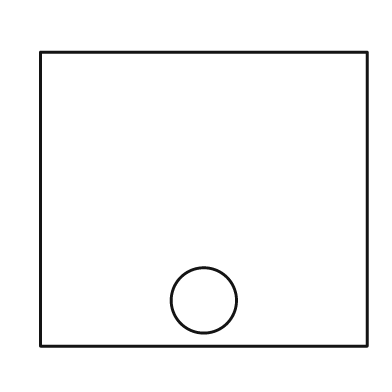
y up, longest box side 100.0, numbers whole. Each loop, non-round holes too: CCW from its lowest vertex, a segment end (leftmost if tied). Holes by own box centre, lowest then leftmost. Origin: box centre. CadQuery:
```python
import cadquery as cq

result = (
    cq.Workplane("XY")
    .moveTo(-50.0, -45.0)
    .lineTo(50.0, -45.0)
    .lineTo(50.0, 45.0)
    .lineTo(-50.0, 45.0)
    .close()
    .moveTo(0.0, -31.0)
    .circle(10.0)
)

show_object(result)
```